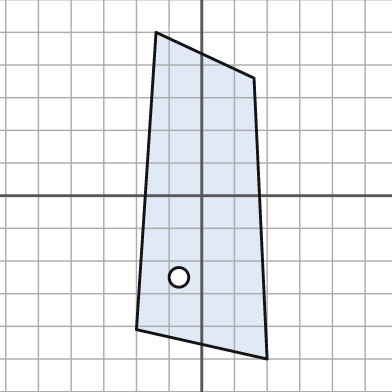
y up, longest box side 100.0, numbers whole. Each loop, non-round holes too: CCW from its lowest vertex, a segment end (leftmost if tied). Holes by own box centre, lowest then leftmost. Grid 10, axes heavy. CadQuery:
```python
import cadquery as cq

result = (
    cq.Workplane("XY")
    .moveTo(20.0, -50.0)
    .lineTo(16.0, 36.0)
    .lineTo(-14.0, 50.0)
    .lineTo(-20.0, -41.0)
    .close()
    .moveTo(-7.0, -25.0)
    .circle(3.0)
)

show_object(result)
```